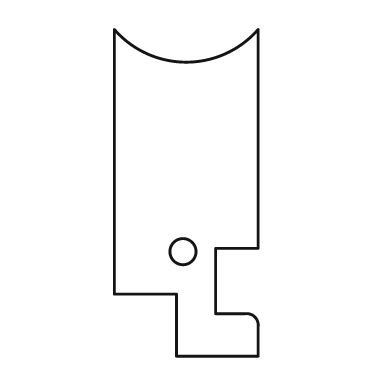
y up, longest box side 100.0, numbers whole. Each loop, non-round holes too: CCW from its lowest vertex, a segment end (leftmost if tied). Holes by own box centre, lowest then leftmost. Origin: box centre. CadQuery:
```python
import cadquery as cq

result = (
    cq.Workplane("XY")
    .moveTo(-3.0, -50.0)
    .lineTo(22.0, -50.0)
    .lineTo(22.0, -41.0)
    .threePointArc((21.0, -38.0), (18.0, -37.0))
    .lineTo(9.0, -37.0)
    .lineTo(9.0, -17.0)
    .lineTo(22.0, -17.0)
    .lineTo(22.0, 50.0)
    .threePointArc((0.0, 40.0), (-22.0, 50.0))
    .lineTo(-22.0, -31.0)
    .lineTo(-3.0, -31.0)
    .close()
    .moveTo(-1.0, -18.0)
    .circle(4.0)
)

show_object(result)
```